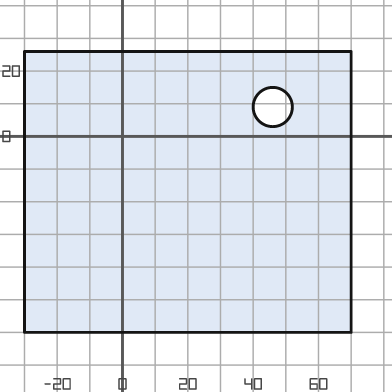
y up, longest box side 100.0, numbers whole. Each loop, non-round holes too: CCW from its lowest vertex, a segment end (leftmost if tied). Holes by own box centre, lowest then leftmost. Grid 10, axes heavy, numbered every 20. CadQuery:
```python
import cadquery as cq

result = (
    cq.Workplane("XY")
    .moveTo(-30.0, -60.0)
    .lineTo(70.0, -60.0)
    .lineTo(70.0, 26.0)
    .lineTo(-30.0, 26.0)
    .close()
    .moveTo(46.0, 9.0)
    .circle(6.0)
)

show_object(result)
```